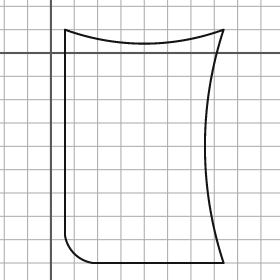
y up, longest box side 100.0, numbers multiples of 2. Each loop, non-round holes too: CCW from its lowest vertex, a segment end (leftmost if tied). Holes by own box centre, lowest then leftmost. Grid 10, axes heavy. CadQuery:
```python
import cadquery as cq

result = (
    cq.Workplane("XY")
    .moveTo(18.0, -90.0)
    .lineTo(74.0, -90.0)
    .threePointArc((66.0, -40.0), (74.0, 10.0))
    .threePointArc((40.0, 4.0), (6.0, 10.0))
    .lineTo(6.0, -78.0)
    .threePointArc((10.0, -86.0), (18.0, -90.0))
    .close()
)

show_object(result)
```